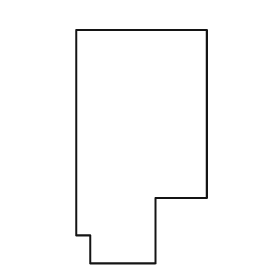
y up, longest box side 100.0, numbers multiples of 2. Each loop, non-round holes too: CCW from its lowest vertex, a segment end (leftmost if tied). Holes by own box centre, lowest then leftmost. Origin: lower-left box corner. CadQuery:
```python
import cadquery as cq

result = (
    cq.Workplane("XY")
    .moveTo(6.0, 0.0)
    .lineTo(34.0, 0.0)
    .lineTo(34.0, 28.0)
    .lineTo(56.0, 28.0)
    .lineTo(56.0, 100.0)
    .lineTo(0.0, 100.0)
    .lineTo(0.0, 12.0)
    .lineTo(6.0, 12.0)
    .close()
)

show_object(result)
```